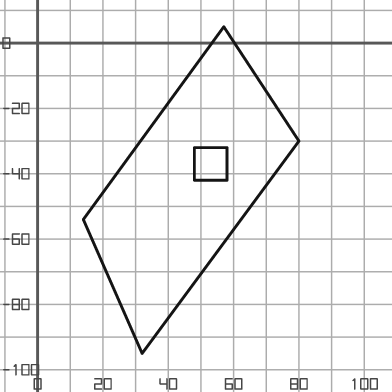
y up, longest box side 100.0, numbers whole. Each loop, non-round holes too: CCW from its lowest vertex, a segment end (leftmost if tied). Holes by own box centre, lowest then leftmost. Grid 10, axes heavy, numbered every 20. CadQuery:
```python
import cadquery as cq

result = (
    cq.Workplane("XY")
    .moveTo(32.0, -95.0)
    .lineTo(80.0, -30.0)
    .lineTo(57.0, 5.0)
    .lineTo(14.0, -54.0)
    .close()
    .moveTo(48.0, -42.0)
    .lineTo(58.0, -42.0)
    .lineTo(58.0, -32.0)
    .lineTo(48.0, -32.0)
    .close()
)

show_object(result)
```